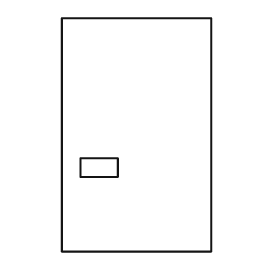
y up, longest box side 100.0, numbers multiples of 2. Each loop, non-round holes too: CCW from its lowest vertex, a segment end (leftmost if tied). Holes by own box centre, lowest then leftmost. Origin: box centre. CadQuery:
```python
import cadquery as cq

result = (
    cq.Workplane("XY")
    .moveTo(-32.0, -50.0)
    .lineTo(32.0, -50.0)
    .lineTo(32.0, 50.0)
    .lineTo(-32.0, 50.0)
    .close()
    .moveTo(-24.0, -18.0)
    .lineTo(-8.0, -18.0)
    .lineTo(-8.0, -10.0)
    .lineTo(-24.0, -10.0)
    .close()
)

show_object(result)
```